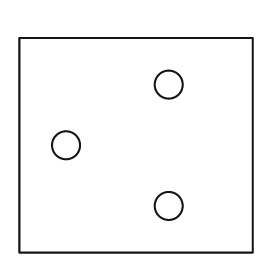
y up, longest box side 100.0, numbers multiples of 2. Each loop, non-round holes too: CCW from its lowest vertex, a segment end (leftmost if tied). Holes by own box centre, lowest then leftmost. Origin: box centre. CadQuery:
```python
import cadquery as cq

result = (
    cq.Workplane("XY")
    .moveTo(-50.0, -46.0)
    .lineTo(50.0, -46.0)
    .lineTo(50.0, 46.0)
    .lineTo(-50.0, 46.0)
    .close()
    .moveTo(14.0, -26.0)
    .circle(6.0)
    .moveTo(-30.0, 0.0)
    .circle(6.0)
    .moveTo(14.0, 26.0)
    .circle(6.0)
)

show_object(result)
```